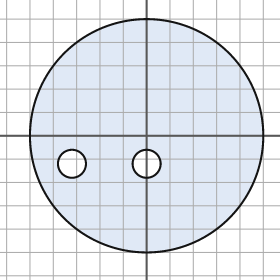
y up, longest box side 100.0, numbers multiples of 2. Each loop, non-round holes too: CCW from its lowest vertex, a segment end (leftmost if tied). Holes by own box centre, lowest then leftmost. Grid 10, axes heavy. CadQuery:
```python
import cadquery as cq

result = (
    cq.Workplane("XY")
    .moveTo(0.0, 0.0)
    .circle(50.0)
    .moveTo(-32.0, -12.0)
    .circle(6.0)
    .moveTo(0.0, -12.0)
    .circle(6.0)
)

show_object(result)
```